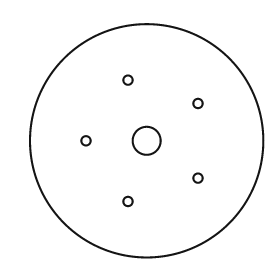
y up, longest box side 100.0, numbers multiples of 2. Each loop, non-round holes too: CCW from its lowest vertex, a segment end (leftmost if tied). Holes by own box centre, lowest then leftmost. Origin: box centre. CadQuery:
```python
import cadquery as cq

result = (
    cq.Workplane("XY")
    .moveTo(0.0, 0.0)
    .circle(50.0)
    .moveTo(-8.0, -26.0)
    .circle(2.0)
    .moveTo(22.0, -16.0)
    .circle(2.0)
    .moveTo(-26.0, 0.0)
    .circle(2.0)
    .moveTo(0.0, 0.0)
    .circle(6.0)
    .moveTo(22.0, 16.0)
    .circle(2.0)
    .moveTo(-8.0, 26.0)
    .circle(2.0)
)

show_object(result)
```